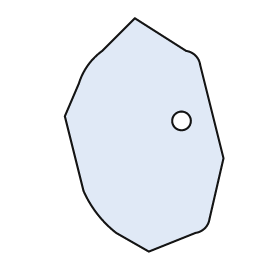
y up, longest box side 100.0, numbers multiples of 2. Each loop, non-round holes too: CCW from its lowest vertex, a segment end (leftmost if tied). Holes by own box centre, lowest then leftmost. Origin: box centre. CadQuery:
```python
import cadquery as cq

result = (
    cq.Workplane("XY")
    .moveTo(2.0, -50.0)
    .lineTo(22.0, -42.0)
    .threePointArc((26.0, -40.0), (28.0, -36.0))
    .lineTo(34.0, -10.0)
    .lineTo(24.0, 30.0)
    .threePointArc((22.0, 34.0), (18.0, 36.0))
    .lineTo(-4.0, 50.0)
    .lineTo(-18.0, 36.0)
    .threePointArc((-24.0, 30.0), (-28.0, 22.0))
    .lineTo(-34.0, 8.0)
    .lineTo(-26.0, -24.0)
    .threePointArc((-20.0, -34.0), (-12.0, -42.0))
    .close()
    .moveTo(16.0, 6.0)
    .circle(4.0)
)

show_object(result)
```